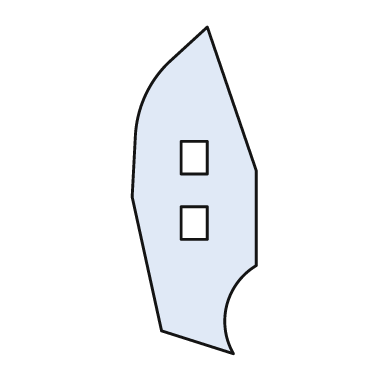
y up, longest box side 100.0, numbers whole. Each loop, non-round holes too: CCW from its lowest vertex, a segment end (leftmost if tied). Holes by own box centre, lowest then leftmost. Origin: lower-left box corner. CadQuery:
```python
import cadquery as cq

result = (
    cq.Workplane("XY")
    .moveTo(31.0, 0.0)
    .threePointArc((29.0, 15.0), (38.0, 27.0))
    .lineTo(38.0, 56.0)
    .lineTo(23.0, 100.0)
    .lineTo(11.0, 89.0)
    .threePointArc((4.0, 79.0), (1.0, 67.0))
    .lineTo(0.0, 48.0)
    .lineTo(9.0, 7.0)
    .close()
    .moveTo(15.0, 35.0)
    .lineTo(23.0, 35.0)
    .lineTo(23.0, 45.0)
    .lineTo(15.0, 45.0)
    .close()
    .moveTo(15.0, 55.0)
    .lineTo(23.0, 55.0)
    .lineTo(23.0, 65.0)
    .lineTo(15.0, 65.0)
    .close()
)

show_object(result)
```